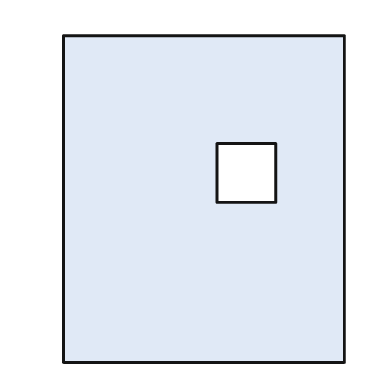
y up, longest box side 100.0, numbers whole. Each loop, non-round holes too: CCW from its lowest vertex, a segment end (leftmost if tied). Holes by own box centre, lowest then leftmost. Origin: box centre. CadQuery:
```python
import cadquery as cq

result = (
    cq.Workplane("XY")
    .moveTo(-43.0, -50.0)
    .lineTo(43.0, -50.0)
    .lineTo(43.0, 50.0)
    .lineTo(-43.0, 50.0)
    .close()
    .moveTo(4.0, -1.0)
    .lineTo(22.0, -1.0)
    .lineTo(22.0, 17.0)
    .lineTo(4.0, 17.0)
    .close()
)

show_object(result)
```